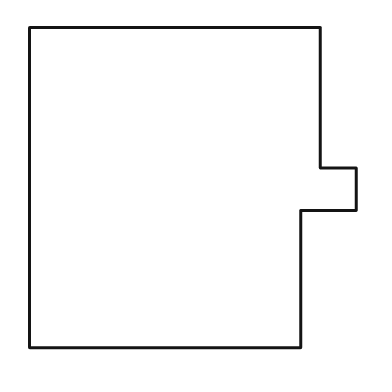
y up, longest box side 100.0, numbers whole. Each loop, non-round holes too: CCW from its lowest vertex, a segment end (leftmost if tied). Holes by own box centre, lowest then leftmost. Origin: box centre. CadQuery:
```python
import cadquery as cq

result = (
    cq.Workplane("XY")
    .moveTo(-50.0, -49.0)
    .lineTo(33.0, -49.0)
    .lineTo(33.0, -7.0)
    .lineTo(50.0, -7.0)
    .lineTo(50.0, 6.0)
    .lineTo(39.0, 6.0)
    .lineTo(39.0, 49.0)
    .lineTo(-50.0, 49.0)
    .close()
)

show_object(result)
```